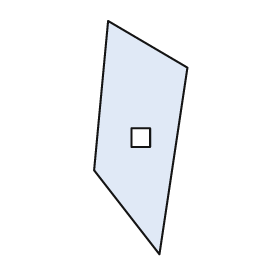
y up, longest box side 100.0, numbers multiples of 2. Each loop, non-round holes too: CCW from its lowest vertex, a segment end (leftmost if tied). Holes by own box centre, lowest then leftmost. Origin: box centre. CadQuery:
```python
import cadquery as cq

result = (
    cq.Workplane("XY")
    .moveTo(8.0, -50.0)
    .lineTo(20.0, 30.0)
    .lineTo(-14.0, 50.0)
    .lineTo(-20.0, -14.0)
    .close()
    .moveTo(-4.0, -4.0)
    .lineTo(4.0, -4.0)
    .lineTo(4.0, 4.0)
    .lineTo(-4.0, 4.0)
    .close()
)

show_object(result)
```